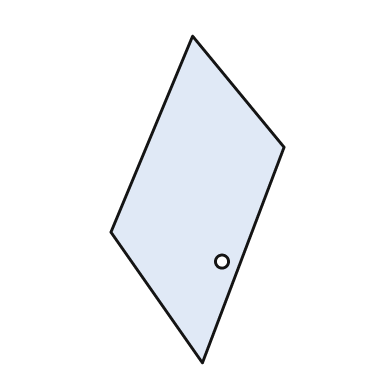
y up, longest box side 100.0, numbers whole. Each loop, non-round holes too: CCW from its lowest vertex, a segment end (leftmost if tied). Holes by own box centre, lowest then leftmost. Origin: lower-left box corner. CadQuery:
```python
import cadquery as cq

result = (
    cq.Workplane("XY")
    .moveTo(28.0, 0.0)
    .lineTo(53.0, 66.0)
    .lineTo(25.0, 100.0)
    .lineTo(0.0, 40.0)
    .close()
    .moveTo(34.0, 31.0)
    .circle(2.0)
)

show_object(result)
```